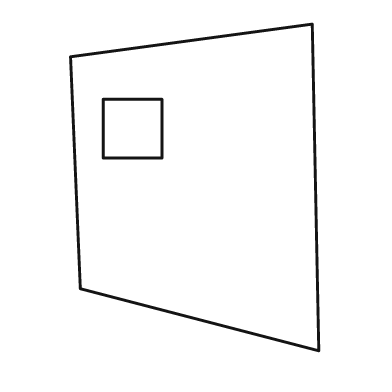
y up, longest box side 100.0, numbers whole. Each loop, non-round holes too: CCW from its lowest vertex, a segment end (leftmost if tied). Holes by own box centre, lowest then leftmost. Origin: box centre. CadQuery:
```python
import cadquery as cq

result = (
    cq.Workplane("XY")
    .moveTo(38.0, -50.0)
    .lineTo(36.0, 50.0)
    .lineTo(-38.0, 40.0)
    .lineTo(-35.0, -31.0)
    .close()
    .moveTo(-28.0, 9.0)
    .lineTo(-10.0, 9.0)
    .lineTo(-10.0, 27.0)
    .lineTo(-28.0, 27.0)
    .close()
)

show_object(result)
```